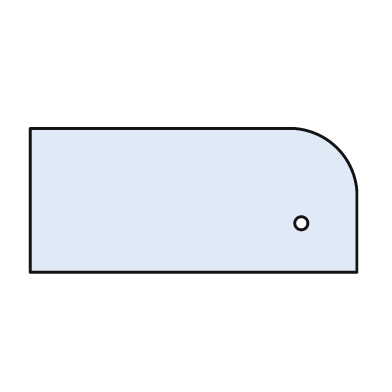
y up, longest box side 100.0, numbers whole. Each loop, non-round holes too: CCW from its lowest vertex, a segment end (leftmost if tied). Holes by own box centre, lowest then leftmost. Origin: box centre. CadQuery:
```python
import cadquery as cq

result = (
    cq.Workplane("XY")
    .moveTo(-50.0, -22.0)
    .lineTo(50.0, -22.0)
    .lineTo(50.0, 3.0)
    .threePointArc((44.0, 16.0), (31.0, 22.0))
    .lineTo(-50.0, 22.0)
    .close()
    .moveTo(33.0, -7.0)
    .circle(2.0)
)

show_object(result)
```